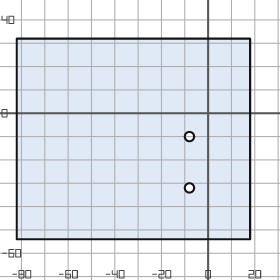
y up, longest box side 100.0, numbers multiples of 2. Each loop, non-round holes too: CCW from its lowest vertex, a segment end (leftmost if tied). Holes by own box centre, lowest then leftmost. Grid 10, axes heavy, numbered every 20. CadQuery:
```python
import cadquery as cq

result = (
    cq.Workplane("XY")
    .moveTo(-82.0, -54.0)
    .lineTo(18.0, -54.0)
    .lineTo(18.0, 32.0)
    .lineTo(-82.0, 32.0)
    .close()
    .moveTo(-8.0, -32.0)
    .circle(2.0)
    .moveTo(-8.0, -10.0)
    .circle(2.0)
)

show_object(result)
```